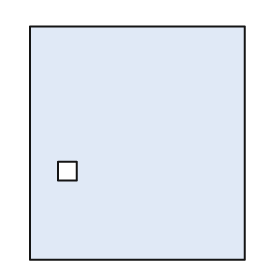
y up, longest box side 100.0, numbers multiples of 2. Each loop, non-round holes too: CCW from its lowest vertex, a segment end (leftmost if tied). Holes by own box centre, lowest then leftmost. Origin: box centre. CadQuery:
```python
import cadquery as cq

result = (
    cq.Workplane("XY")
    .moveTo(-46.0, -50.0)
    .lineTo(46.0, -50.0)
    .lineTo(46.0, 50.0)
    .lineTo(-46.0, 50.0)
    .close()
    .moveTo(-34.0, -16.0)
    .lineTo(-26.0, -16.0)
    .lineTo(-26.0, -8.0)
    .lineTo(-34.0, -8.0)
    .close()
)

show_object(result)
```